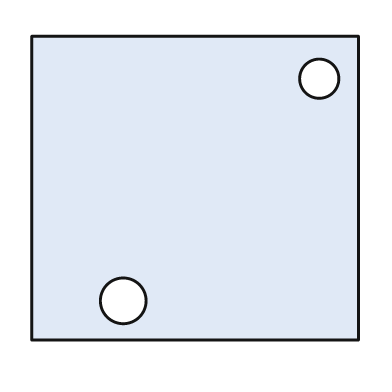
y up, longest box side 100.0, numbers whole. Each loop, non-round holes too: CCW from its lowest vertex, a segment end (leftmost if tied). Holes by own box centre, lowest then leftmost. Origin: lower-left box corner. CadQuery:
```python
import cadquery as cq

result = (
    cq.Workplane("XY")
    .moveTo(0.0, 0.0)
    .lineTo(100.0, 0.0)
    .lineTo(100.0, 93.0)
    .lineTo(0.0, 93.0)
    .close()
    .moveTo(28.0, 12.0)
    .circle(7.0)
    .moveTo(88.0, 80.0)
    .circle(6.0)
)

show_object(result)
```